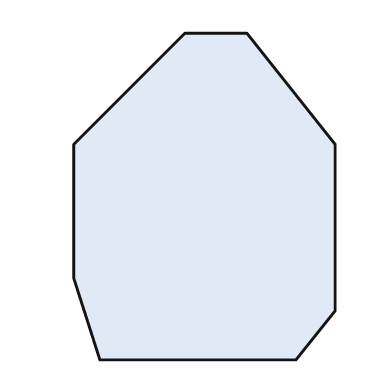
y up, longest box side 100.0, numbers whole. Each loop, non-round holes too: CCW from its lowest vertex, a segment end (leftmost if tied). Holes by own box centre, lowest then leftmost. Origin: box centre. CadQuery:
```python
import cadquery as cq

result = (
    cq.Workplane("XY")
    .moveTo(-32.0, -50.0)
    .lineTo(28.0, -50.0)
    .lineTo(40.0, -35.0)
    .lineTo(40.0, 16.0)
    .lineTo(13.0, 50.0)
    .lineTo(-6.0, 50.0)
    .lineTo(-40.0, 16.0)
    .lineTo(-40.0, -25.0)
    .close()
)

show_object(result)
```